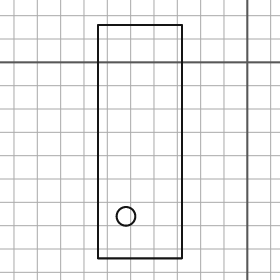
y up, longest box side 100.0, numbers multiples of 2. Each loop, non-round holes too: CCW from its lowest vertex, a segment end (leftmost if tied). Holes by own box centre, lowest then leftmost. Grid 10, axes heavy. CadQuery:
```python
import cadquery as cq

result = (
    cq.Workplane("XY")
    .moveTo(-64.0, -84.0)
    .lineTo(-28.0, -84.0)
    .lineTo(-28.0, 16.0)
    .lineTo(-64.0, 16.0)
    .close()
    .moveTo(-52.0, -66.0)
    .circle(4.0)
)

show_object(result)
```